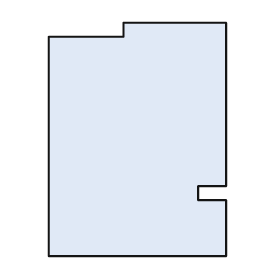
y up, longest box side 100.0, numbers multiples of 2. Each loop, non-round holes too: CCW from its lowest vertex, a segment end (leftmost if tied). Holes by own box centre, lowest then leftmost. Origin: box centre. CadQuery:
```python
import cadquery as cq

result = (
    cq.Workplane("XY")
    .moveTo(-38.0, -50.0)
    .lineTo(38.0, -50.0)
    .lineTo(38.0, -26.0)
    .lineTo(26.0, -26.0)
    .lineTo(26.0, -20.0)
    .lineTo(38.0, -20.0)
    .lineTo(38.0, 50.0)
    .lineTo(-6.0, 50.0)
    .lineTo(-6.0, 44.0)
    .lineTo(-38.0, 44.0)
    .close()
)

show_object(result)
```